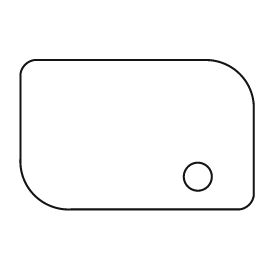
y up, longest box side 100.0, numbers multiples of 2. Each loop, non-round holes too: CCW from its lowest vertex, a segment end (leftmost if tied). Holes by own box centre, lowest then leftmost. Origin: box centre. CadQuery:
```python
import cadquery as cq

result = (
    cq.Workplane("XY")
    .moveTo(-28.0, -32.0)
    .lineTo(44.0, -32.0)
    .threePointArc((48.0, -30.0), (50.0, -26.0))
    .lineTo(50.0, 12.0)
    .threePointArc((44.0, 26.0), (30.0, 32.0))
    .lineTo(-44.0, 32.0)
    .threePointArc((-48.0, 30.0), (-50.0, 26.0))
    .lineTo(-50.0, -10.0)
    .threePointArc((-44.0, -26.0), (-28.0, -32.0))
    .close()
    .moveTo(26.0, -18.0)
    .circle(6.0)
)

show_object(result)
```